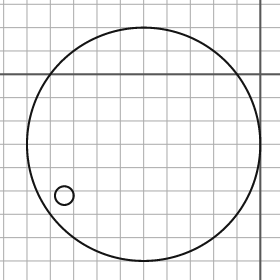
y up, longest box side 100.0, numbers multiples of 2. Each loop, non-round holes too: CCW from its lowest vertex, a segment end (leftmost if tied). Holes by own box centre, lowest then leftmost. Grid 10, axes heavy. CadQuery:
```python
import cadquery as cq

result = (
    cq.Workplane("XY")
    .moveTo(-50.0, -30.0)
    .circle(50.0)
    .moveTo(-84.0, -52.0)
    .circle(4.0)
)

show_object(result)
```